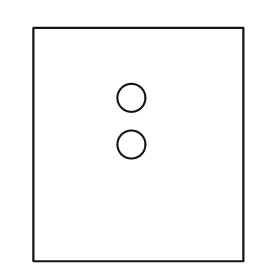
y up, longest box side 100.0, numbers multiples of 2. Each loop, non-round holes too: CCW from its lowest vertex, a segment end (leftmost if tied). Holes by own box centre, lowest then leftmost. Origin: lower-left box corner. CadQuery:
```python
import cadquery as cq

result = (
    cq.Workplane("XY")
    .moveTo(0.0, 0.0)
    .lineTo(90.0, 0.0)
    .lineTo(90.0, 100.0)
    .lineTo(0.0, 100.0)
    .close()
    .moveTo(42.0, 50.0)
    .circle(6.0)
    .moveTo(42.0, 70.0)
    .circle(6.0)
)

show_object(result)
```